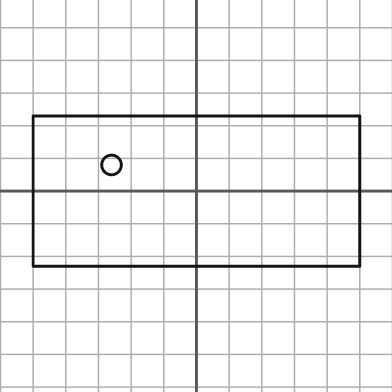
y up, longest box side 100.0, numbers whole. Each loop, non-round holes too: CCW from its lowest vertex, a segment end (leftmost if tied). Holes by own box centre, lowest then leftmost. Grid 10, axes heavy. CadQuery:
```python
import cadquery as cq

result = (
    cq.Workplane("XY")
    .moveTo(-50.0, -23.0)
    .lineTo(50.0, -23.0)
    .lineTo(50.0, 23.0)
    .lineTo(-50.0, 23.0)
    .close()
    .moveTo(-26.0, 8.0)
    .circle(3.0)
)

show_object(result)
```